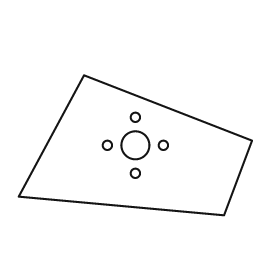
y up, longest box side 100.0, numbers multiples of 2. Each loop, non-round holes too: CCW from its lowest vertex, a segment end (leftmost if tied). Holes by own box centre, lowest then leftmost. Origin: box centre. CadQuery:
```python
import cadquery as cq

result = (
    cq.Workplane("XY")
    .moveTo(38.0, -30.0)
    .lineTo(50.0, 2.0)
    .lineTo(-22.0, 30.0)
    .lineTo(-50.0, -22.0)
    .close()
    .moveTo(0.0, -12.0)
    .circle(2.0)
    .moveTo(-12.0, 0.0)
    .circle(2.0)
    .moveTo(0.0, 0.0)
    .circle(6.0)
    .moveTo(12.0, 0.0)
    .circle(2.0)
    .moveTo(0.0, 12.0)
    .circle(2.0)
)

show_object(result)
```